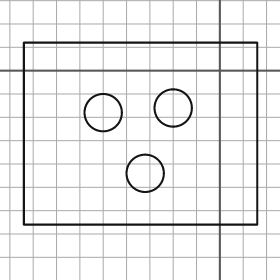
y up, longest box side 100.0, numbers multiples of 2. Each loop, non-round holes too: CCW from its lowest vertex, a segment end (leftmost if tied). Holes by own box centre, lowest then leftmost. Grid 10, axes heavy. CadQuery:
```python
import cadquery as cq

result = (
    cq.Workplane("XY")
    .moveTo(-84.0, -66.0)
    .lineTo(16.0, -66.0)
    .lineTo(16.0, 12.0)
    .lineTo(-84.0, 12.0)
    .close()
    .moveTo(-32.0, -44.0)
    .circle(8.0)
    .moveTo(-50.0, -18.0)
    .circle(8.0)
    .moveTo(-20.0, -16.0)
    .circle(8.0)
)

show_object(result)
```